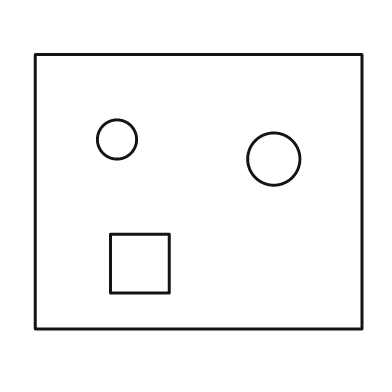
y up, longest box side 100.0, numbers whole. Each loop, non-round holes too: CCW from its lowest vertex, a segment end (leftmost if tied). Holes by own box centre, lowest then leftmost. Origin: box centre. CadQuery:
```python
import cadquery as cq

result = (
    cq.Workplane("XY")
    .moveTo(-50.0, -42.0)
    .lineTo(50.0, -42.0)
    .lineTo(50.0, 42.0)
    .lineTo(-50.0, 42.0)
    .close()
    .moveTo(-27.0, -31.0)
    .lineTo(-9.0, -31.0)
    .lineTo(-9.0, -13.0)
    .lineTo(-27.0, -13.0)
    .close()
    .moveTo(23.0, 10.0)
    .circle(8.0)
    .moveTo(-25.0, 16.0)
    .circle(6.0)
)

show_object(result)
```